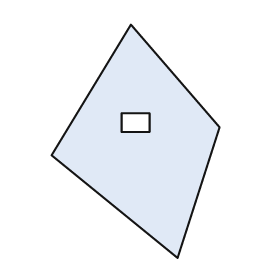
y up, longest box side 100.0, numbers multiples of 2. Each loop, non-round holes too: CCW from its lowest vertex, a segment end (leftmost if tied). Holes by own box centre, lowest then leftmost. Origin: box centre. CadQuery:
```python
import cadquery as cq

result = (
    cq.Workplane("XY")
    .moveTo(18.0, -50.0)
    .lineTo(36.0, 6.0)
    .lineTo(-2.0, 50.0)
    .lineTo(-36.0, -6.0)
    .close()
    .moveTo(-6.0, 4.0)
    .lineTo(6.0, 4.0)
    .lineTo(6.0, 12.0)
    .lineTo(-6.0, 12.0)
    .close()
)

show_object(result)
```